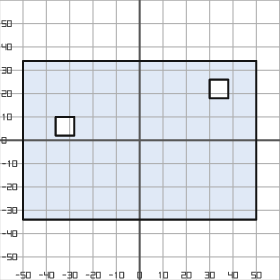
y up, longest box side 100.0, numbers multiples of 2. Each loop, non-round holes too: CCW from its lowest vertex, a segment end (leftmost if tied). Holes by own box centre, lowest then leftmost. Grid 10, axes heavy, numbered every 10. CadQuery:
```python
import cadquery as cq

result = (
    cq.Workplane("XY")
    .moveTo(-50.0, -34.0)
    .lineTo(50.0, -34.0)
    .lineTo(50.0, 34.0)
    .lineTo(-50.0, 34.0)
    .close()
    .moveTo(-36.0, 2.0)
    .lineTo(-28.0, 2.0)
    .lineTo(-28.0, 10.0)
    .lineTo(-36.0, 10.0)
    .close()
    .moveTo(30.0, 18.0)
    .lineTo(38.0, 18.0)
    .lineTo(38.0, 26.0)
    .lineTo(30.0, 26.0)
    .close()
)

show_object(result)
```